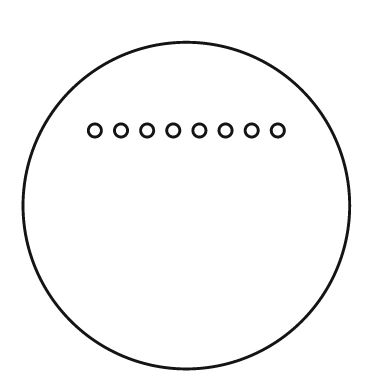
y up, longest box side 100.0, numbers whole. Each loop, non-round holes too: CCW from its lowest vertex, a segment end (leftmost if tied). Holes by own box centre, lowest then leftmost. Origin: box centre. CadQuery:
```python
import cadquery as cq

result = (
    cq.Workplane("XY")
    .moveTo(0.0, 0.0)
    .circle(50.0)
    .moveTo(-28.0, 23.0)
    .circle(2.0)
    .moveTo(-20.0, 23.0)
    .circle(2.0)
    .moveTo(-12.0, 23.0)
    .circle(2.0)
    .moveTo(-4.0, 23.0)
    .circle(2.0)
    .moveTo(4.0, 23.0)
    .circle(2.0)
    .moveTo(12.0, 23.0)
    .circle(2.0)
    .moveTo(20.0, 23.0)
    .circle(2.0)
    .moveTo(28.0, 23.0)
    .circle(2.0)
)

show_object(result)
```